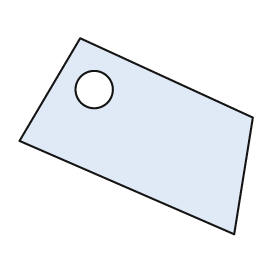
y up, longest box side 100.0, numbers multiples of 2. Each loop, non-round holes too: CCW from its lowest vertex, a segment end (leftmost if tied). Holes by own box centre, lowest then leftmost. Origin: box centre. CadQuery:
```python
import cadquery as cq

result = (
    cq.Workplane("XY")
    .moveTo(42.0, -42.0)
    .lineTo(50.0, 8.0)
    .lineTo(-24.0, 42.0)
    .lineTo(-50.0, -2.0)
    .close()
    .moveTo(-18.0, 20.0)
    .circle(8.0)
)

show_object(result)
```